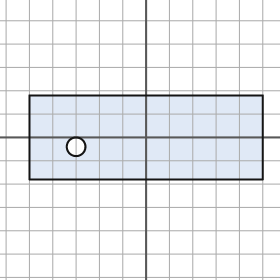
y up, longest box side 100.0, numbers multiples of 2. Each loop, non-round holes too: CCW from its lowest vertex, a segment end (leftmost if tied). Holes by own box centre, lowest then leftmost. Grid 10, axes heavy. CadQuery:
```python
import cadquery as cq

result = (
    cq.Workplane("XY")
    .moveTo(-50.0, -18.0)
    .lineTo(50.0, -18.0)
    .lineTo(50.0, 18.0)
    .lineTo(-50.0, 18.0)
    .close()
    .moveTo(-30.0, -4.0)
    .circle(4.0)
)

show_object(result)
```